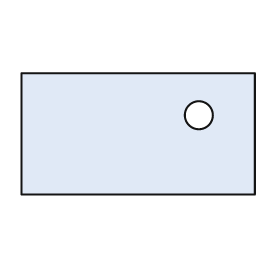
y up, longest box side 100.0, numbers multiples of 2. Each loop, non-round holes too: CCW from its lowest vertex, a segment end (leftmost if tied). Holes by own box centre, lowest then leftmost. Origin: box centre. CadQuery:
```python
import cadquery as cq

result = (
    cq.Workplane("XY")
    .moveTo(-50.0, -26.0)
    .lineTo(50.0, -26.0)
    .lineTo(50.0, 26.0)
    .lineTo(-50.0, 26.0)
    .close()
    .moveTo(26.0, 8.0)
    .circle(6.0)
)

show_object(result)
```